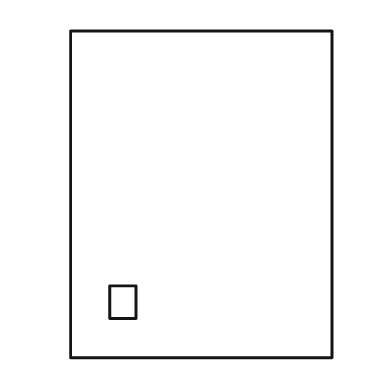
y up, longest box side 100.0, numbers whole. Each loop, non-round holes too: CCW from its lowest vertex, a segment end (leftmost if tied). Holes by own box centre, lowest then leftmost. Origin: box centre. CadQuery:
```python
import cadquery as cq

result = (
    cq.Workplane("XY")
    .moveTo(-40.0, -50.0)
    .lineTo(40.0, -50.0)
    .lineTo(40.0, 50.0)
    .lineTo(-40.0, 50.0)
    .close()
    .moveTo(-28.0, -38.0)
    .lineTo(-20.0, -38.0)
    .lineTo(-20.0, -28.0)
    .lineTo(-28.0, -28.0)
    .close()
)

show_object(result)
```